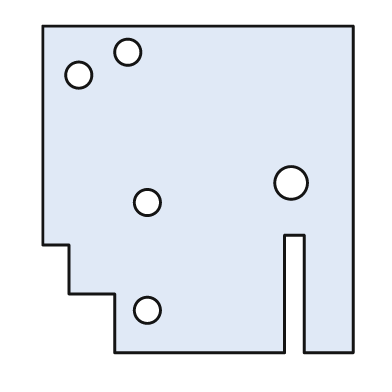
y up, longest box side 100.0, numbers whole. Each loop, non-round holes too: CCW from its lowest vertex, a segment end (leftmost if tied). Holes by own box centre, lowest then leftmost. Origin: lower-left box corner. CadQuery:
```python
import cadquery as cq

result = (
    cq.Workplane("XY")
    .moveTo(22.0, 0.0)
    .lineTo(74.0, 0.0)
    .lineTo(74.0, 36.0)
    .lineTo(80.0, 36.0)
    .lineTo(80.0, 0.0)
    .lineTo(95.0, 0.0)
    .lineTo(95.0, 100.0)
    .lineTo(0.0, 100.0)
    .lineTo(0.0, 33.0)
    .lineTo(8.0, 33.0)
    .lineTo(8.0, 18.0)
    .lineTo(22.0, 18.0)
    .close()
    .moveTo(32.0, 13.0)
    .circle(4.0)
    .moveTo(32.0, 46.0)
    .circle(4.0)
    .moveTo(76.0, 52.0)
    .circle(5.0)
    .moveTo(11.0, 85.0)
    .circle(4.0)
    .moveTo(26.0, 92.0)
    .circle(4.0)
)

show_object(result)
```